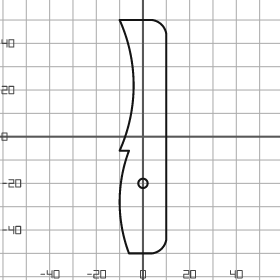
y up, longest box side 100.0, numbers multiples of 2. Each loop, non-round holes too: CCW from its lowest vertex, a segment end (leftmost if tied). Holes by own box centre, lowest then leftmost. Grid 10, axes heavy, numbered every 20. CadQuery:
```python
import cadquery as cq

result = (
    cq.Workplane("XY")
    .moveTo(-6.0, -50.0)
    .lineTo(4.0, -50.0)
    .threePointArc((8.0, -48.0), (10.0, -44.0))
    .lineTo(10.0, 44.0)
    .threePointArc((8.0, 48.0), (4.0, 50.0))
    .lineTo(-10.0, 50.0)
    .threePointArc((-4.0, 22.0), (-10.0, -6.0))
    .lineTo(-6.0, -6.0)
    .threePointArc((-10.0, -28.0), (-6.0, -50.0))
    .close()
    .moveTo(0.0, -20.0)
    .circle(2.0)
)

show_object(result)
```